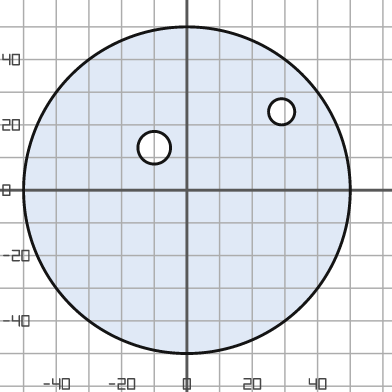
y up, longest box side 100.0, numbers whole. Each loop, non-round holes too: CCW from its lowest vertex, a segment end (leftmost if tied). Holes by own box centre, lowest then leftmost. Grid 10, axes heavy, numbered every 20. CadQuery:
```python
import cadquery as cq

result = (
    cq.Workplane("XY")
    .moveTo(0.0, 0.0)
    .circle(50.0)
    .moveTo(-10.0, 13.0)
    .circle(5.0)
    .moveTo(29.0, 24.0)
    .circle(4.0)
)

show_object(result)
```